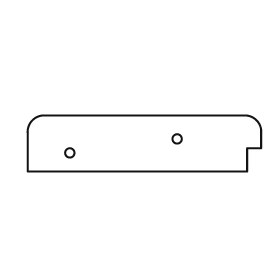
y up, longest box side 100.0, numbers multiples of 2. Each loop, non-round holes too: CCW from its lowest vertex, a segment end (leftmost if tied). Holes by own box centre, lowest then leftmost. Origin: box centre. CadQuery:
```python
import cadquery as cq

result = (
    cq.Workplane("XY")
    .moveTo(-50.0, -12.0)
    .lineTo(44.0, -12.0)
    .lineTo(44.0, -2.0)
    .lineTo(50.0, -2.0)
    .lineTo(50.0, 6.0)
    .threePointArc((48.0, 10.0), (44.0, 12.0))
    .lineTo(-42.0, 12.0)
    .threePointArc((-48.0, 10.0), (-50.0, 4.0))
    .close()
    .moveTo(-32.0, -4.0)
    .circle(2.0)
    .moveTo(14.0, 2.0)
    .circle(2.0)
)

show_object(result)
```